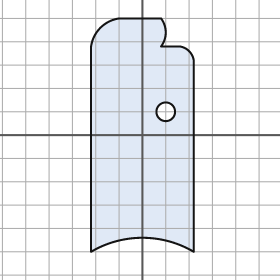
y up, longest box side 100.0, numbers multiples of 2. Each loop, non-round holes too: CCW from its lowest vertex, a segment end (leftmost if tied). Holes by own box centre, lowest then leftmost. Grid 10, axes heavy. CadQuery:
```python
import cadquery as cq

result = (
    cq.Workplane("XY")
    .moveTo(-22.0, -50.0)
    .threePointArc((0.0, -44.0), (22.0, -50.0))
    .lineTo(22.0, 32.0)
    .threePointArc((20.0, 36.0), (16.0, 38.0))
    .lineTo(8.0, 38.0)
    .threePointArc((10.0, 44.0), (8.0, 50.0))
    .lineTo(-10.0, 50.0)
    .threePointArc((-18.0, 46.0), (-22.0, 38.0))
    .close()
    .moveTo(10.0, 10.0)
    .circle(4.0)
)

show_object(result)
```